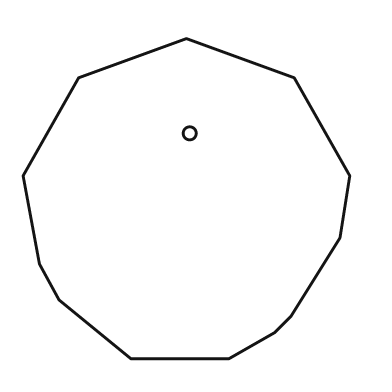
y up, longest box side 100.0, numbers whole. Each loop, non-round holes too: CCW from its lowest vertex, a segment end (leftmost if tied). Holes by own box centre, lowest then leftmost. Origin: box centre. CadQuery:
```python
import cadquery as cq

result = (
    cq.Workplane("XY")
    .moveTo(-17.0, -49.0)
    .lineTo(13.0, -49.0)
    .lineTo(27.0, -41.0)
    .lineTo(32.0, -36.0)
    .lineTo(47.0, -12.0)
    .lineTo(50.0, 7.0)
    .lineTo(33.0, 37.0)
    .lineTo(0.0, 49.0)
    .lineTo(-33.0, 37.0)
    .lineTo(-50.0, 7.0)
    .lineTo(-45.0, -20.0)
    .lineTo(-39.0, -31.0)
    .close()
    .moveTo(1.0, 20.0)
    .circle(2.0)
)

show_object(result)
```